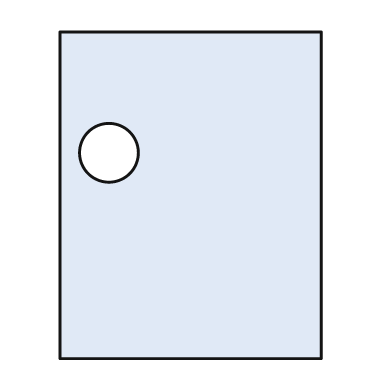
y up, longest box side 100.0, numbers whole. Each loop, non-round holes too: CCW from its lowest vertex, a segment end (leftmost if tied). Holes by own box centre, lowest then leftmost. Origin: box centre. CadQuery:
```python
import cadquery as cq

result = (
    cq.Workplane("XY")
    .moveTo(-40.0, -50.0)
    .lineTo(40.0, -50.0)
    .lineTo(40.0, 50.0)
    .lineTo(-40.0, 50.0)
    .close()
    .moveTo(-25.0, 13.0)
    .circle(9.0)
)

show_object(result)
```